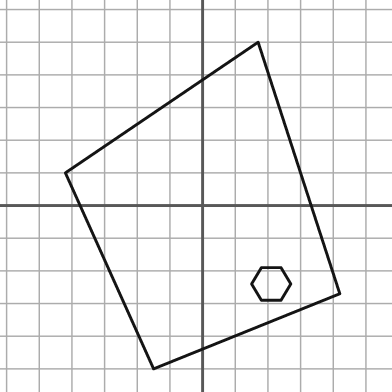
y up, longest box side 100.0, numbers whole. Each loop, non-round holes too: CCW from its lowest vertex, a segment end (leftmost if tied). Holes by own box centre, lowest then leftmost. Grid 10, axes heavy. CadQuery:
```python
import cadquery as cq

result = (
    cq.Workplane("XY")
    .moveTo(-15.0, -50.0)
    .lineTo(42.0, -27.0)
    .lineTo(17.0, 50.0)
    .lineTo(-42.0, 10.0)
    .close()
    .moveTo(18.0, -29.0)
    .lineTo(24.0, -29.0)
    .lineTo(27.0, -24.0)
    .lineTo(24.0, -19.0)
    .lineTo(18.0, -19.0)
    .lineTo(15.0, -24.0)
    .close()
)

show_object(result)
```